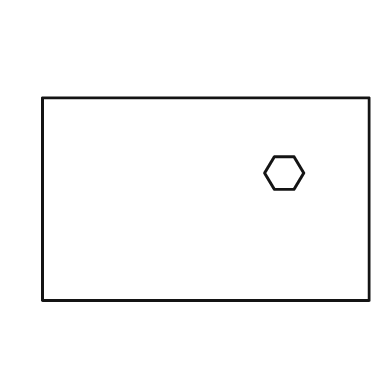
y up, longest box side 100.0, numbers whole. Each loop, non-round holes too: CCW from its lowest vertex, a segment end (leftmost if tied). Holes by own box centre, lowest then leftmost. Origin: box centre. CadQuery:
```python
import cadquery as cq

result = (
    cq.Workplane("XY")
    .moveTo(-50.0, -31.0)
    .lineTo(50.0, -31.0)
    .lineTo(50.0, 31.0)
    .lineTo(-50.0, 31.0)
    .close()
    .moveTo(21.0, 3.0)
    .lineTo(27.0, 3.0)
    .lineTo(30.0, 8.0)
    .lineTo(27.0, 13.0)
    .lineTo(21.0, 13.0)
    .lineTo(18.0, 8.0)
    .close()
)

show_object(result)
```